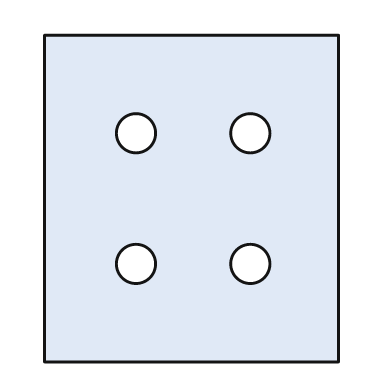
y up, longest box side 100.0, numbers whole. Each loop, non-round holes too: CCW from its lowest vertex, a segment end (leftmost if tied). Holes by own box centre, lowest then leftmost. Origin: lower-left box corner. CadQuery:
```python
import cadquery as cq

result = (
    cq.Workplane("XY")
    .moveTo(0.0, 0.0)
    .lineTo(90.0, 0.0)
    .lineTo(90.0, 100.0)
    .lineTo(0.0, 100.0)
    .close()
    .moveTo(28.0, 30.0)
    .circle(6.0)
    .moveTo(63.0, 30.0)
    .circle(6.0)
    .moveTo(28.0, 70.0)
    .circle(6.0)
    .moveTo(63.0, 70.0)
    .circle(6.0)
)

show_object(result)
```